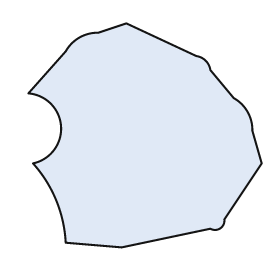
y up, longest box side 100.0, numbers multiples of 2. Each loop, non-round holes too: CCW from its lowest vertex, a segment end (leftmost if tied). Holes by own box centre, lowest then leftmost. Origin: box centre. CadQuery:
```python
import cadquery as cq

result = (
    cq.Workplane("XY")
    .moveTo(-10.0, -48.0)
    .lineTo(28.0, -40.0)
    .threePointArc((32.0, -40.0), (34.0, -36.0))
    .lineTo(50.0, -12.0)
    .lineTo(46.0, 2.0)
    .threePointArc((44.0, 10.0), (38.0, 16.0))
    .lineTo(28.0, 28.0)
    .threePointArc((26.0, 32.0), (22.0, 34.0))
    .lineTo(-8.0, 48.0)
    .lineTo(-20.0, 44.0)
    .threePointArc((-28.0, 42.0), (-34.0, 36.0))
    .lineTo(-50.0, 18.0)
    .threePointArc((-36.0, 4.0), (-48.0, -12.0))
    .threePointArc((-38.0, -28.0), (-34.0, -46.0))
    .close()
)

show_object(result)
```